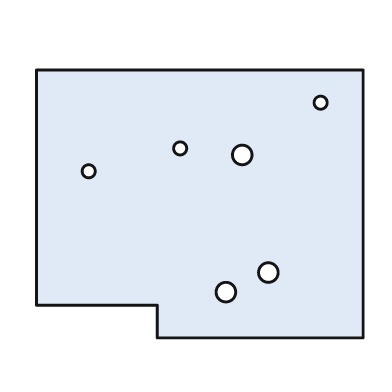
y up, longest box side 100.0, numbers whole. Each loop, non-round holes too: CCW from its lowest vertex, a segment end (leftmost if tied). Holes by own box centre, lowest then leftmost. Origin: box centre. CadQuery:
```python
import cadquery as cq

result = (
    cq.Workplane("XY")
    .moveTo(-13.0, -41.0)
    .lineTo(50.0, -41.0)
    .lineTo(50.0, 41.0)
    .lineTo(-50.0, 41.0)
    .lineTo(-50.0, -31.0)
    .lineTo(-13.0, -31.0)
    .close()
    .moveTo(8.0, -27.0)
    .circle(3.0)
    .moveTo(21.0, -21.0)
    .circle(3.0)
    .moveTo(-34.0, 10.0)
    .circle(2.0)
    .moveTo(13.0, 15.0)
    .circle(3.0)
    .moveTo(-6.0, 17.0)
    .circle(2.0)
    .moveTo(37.0, 31.0)
    .circle(2.0)
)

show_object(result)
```